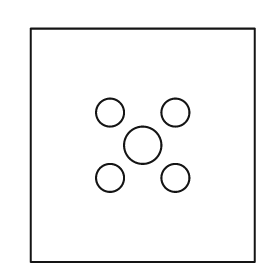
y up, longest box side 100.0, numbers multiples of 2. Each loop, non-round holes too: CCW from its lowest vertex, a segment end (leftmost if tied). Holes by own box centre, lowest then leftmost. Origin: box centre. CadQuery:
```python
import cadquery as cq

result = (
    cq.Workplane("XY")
    .moveTo(-48.0, -50.0)
    .lineTo(48.0, -50.0)
    .lineTo(48.0, 50.0)
    .lineTo(-48.0, 50.0)
    .close()
    .moveTo(-14.0, -14.0)
    .circle(6.0)
    .moveTo(14.0, -14.0)
    .circle(6.0)
    .moveTo(0.0, 0.0)
    .circle(8.0)
    .moveTo(-14.0, 14.0)
    .circle(6.0)
    .moveTo(14.0, 14.0)
    .circle(6.0)
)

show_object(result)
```